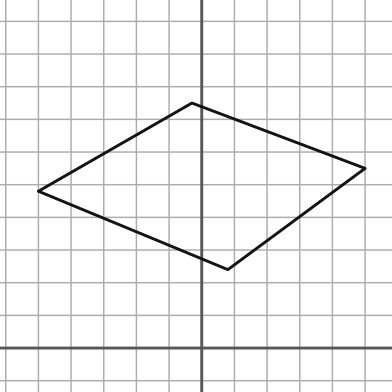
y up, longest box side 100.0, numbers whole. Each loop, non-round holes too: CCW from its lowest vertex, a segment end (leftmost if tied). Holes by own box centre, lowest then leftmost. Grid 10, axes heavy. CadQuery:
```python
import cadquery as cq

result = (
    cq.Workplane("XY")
    .moveTo(8.0, 24.0)
    .lineTo(50.0, 55.0)
    .lineTo(-3.0, 75.0)
    .lineTo(-50.0, 48.0)
    .close()
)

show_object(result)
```